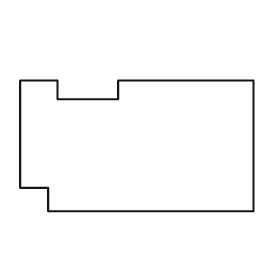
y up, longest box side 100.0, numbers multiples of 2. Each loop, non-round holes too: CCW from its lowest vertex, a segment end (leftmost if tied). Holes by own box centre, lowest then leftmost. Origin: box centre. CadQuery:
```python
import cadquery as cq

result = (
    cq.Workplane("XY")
    .moveTo(-38.0, -28.0)
    .lineTo(50.0, -28.0)
    .lineTo(50.0, 28.0)
    .lineTo(-8.0, 28.0)
    .lineTo(-8.0, 20.0)
    .lineTo(-34.0, 20.0)
    .lineTo(-34.0, 28.0)
    .lineTo(-50.0, 28.0)
    .lineTo(-50.0, -18.0)
    .lineTo(-38.0, -18.0)
    .close()
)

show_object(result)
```